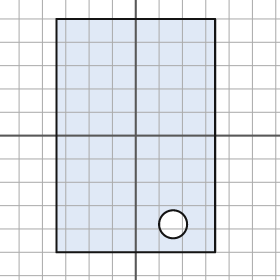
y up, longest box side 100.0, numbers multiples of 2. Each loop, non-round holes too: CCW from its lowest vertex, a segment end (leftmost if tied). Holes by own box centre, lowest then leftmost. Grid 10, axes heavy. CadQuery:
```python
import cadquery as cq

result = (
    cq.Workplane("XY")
    .moveTo(-34.0, -50.0)
    .lineTo(34.0, -50.0)
    .lineTo(34.0, 50.0)
    .lineTo(-34.0, 50.0)
    .close()
    .moveTo(16.0, -38.0)
    .circle(6.0)
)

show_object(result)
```